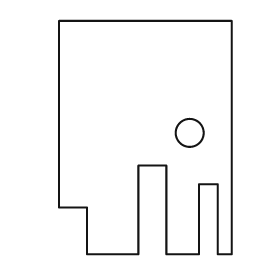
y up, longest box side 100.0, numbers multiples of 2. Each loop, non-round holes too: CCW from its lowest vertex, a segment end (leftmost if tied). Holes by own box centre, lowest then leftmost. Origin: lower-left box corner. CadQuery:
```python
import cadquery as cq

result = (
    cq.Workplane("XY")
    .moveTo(12.0, 0.0)
    .lineTo(34.0, 0.0)
    .lineTo(34.0, 38.0)
    .lineTo(46.0, 38.0)
    .lineTo(46.0, 0.0)
    .lineTo(60.0, 0.0)
    .lineTo(60.0, 30.0)
    .lineTo(68.0, 30.0)
    .lineTo(68.0, 0.0)
    .lineTo(74.0, 0.0)
    .lineTo(74.0, 100.0)
    .lineTo(0.0, 100.0)
    .lineTo(0.0, 20.0)
    .lineTo(12.0, 20.0)
    .close()
    .moveTo(56.0, 52.0)
    .circle(6.0)
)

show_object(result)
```